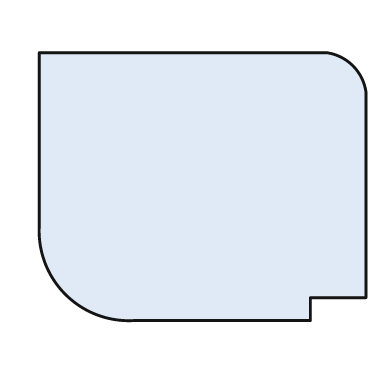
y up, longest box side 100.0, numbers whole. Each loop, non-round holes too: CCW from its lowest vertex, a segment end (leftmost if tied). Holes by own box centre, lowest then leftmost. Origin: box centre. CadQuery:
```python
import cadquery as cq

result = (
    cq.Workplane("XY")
    .moveTo(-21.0, -41.0)
    .lineTo(33.0, -41.0)
    .lineTo(33.0, -34.0)
    .lineTo(50.0, -34.0)
    .lineTo(50.0, 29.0)
    .threePointArc((46.0, 37.0), (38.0, 41.0))
    .lineTo(-50.0, 41.0)
    .lineTo(-50.0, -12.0)
    .threePointArc((-42.0, -33.0), (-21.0, -41.0))
    .close()
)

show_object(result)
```